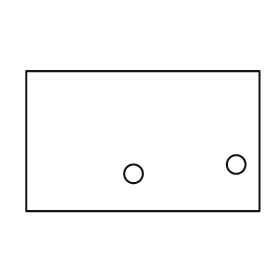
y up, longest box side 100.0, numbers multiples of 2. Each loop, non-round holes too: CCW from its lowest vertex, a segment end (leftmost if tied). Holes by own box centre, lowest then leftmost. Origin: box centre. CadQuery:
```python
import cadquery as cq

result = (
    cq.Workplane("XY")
    .moveTo(-50.0, -30.0)
    .lineTo(50.0, -30.0)
    .lineTo(50.0, 30.0)
    .lineTo(-50.0, 30.0)
    .close()
    .moveTo(-4.0, -14.0)
    .circle(4.0)
    .moveTo(40.0, -10.0)
    .circle(4.0)
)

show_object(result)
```